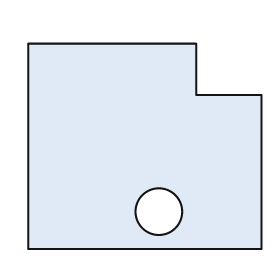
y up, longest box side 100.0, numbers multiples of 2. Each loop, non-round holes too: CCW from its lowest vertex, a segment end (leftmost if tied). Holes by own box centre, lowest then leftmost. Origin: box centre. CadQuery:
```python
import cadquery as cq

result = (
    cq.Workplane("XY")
    .moveTo(-50.0, -44.0)
    .lineTo(50.0, -44.0)
    .lineTo(50.0, 22.0)
    .lineTo(22.0, 22.0)
    .lineTo(22.0, 44.0)
    .lineTo(-50.0, 44.0)
    .close()
    .moveTo(6.0, -28.0)
    .circle(10.0)
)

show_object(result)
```